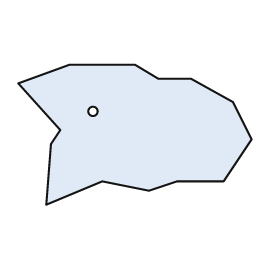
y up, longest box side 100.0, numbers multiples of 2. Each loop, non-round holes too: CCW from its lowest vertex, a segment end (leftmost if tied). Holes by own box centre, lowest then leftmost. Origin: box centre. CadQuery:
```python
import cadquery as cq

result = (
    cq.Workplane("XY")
    .moveTo(-38.0, -30.0)
    .lineTo(-14.0, -20.0)
    .lineTo(6.0, -24.0)
    .lineTo(18.0, -20.0)
    .lineTo(38.0, -20.0)
    .lineTo(50.0, -2.0)
    .lineTo(42.0, 14.0)
    .lineTo(24.0, 24.0)
    .lineTo(10.0, 24.0)
    .lineTo(0.0, 30.0)
    .lineTo(-28.0, 30.0)
    .lineTo(-50.0, 22.0)
    .lineTo(-32.0, 2.0)
    .lineTo(-36.0, -4.0)
    .close()
    .moveTo(-18.0, 10.0)
    .circle(2.0)
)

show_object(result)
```